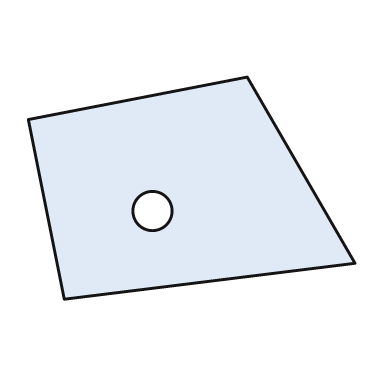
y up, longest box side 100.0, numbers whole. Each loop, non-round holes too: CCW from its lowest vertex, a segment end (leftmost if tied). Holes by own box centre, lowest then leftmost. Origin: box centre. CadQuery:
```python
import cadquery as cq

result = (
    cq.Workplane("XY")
    .moveTo(-39.0, -34.0)
    .lineTo(50.0, -23.0)
    .lineTo(17.0, 34.0)
    .lineTo(-50.0, 21.0)
    .close()
    .moveTo(-12.0, -7.0)
    .circle(6.0)
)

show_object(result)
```